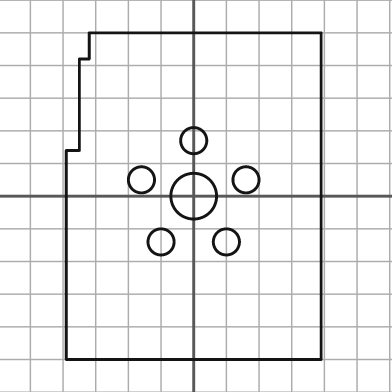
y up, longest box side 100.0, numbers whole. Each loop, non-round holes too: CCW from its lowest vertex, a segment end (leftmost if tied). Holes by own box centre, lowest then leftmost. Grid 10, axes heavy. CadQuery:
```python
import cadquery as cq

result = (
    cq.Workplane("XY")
    .moveTo(-39.0, -50.0)
    .lineTo(39.0, -50.0)
    .lineTo(39.0, 50.0)
    .lineTo(-32.0, 50.0)
    .lineTo(-32.0, 42.0)
    .lineTo(-35.0, 42.0)
    .lineTo(-35.0, 14.0)
    .lineTo(-39.0, 14.0)
    .close()
    .moveTo(-10.0, -14.0)
    .circle(4.0)
    .moveTo(10.0, -14.0)
    .circle(4.0)
    .moveTo(0.0, 0.0)
    .circle(7.0)
    .moveTo(-16.0, 5.0)
    .circle(4.0)
    .moveTo(16.0, 5.0)
    .circle(4.0)
    .moveTo(0.0, 17.0)
    .circle(4.0)
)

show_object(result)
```